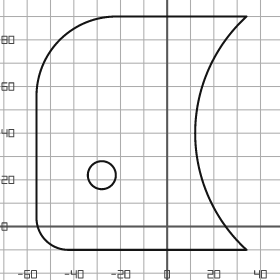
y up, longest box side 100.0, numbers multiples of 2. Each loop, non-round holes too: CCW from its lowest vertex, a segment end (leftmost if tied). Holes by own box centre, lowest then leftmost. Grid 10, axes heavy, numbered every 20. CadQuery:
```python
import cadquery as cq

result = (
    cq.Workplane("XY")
    .moveTo(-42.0, -10.0)
    .lineTo(34.0, -10.0)
    .threePointArc((12.0, 40.0), (34.0, 90.0))
    .lineTo(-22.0, 90.0)
    .threePointArc((-46.0, 80.0), (-56.0, 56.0))
    .lineTo(-56.0, 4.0)
    .threePointArc((-52.0, -6.0), (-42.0, -10.0))
    .close()
    .moveTo(-28.0, 22.0)
    .circle(6.0)
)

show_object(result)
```